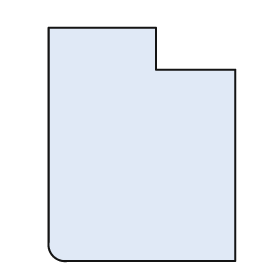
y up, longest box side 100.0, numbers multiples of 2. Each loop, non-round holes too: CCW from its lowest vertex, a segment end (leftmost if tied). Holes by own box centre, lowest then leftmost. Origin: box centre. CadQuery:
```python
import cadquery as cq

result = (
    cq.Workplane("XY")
    .moveTo(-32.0, -50.0)
    .lineTo(40.0, -50.0)
    .lineTo(40.0, 32.0)
    .lineTo(6.0, 32.0)
    .lineTo(6.0, 50.0)
    .lineTo(-40.0, 50.0)
    .lineTo(-40.0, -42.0)
    .threePointArc((-38.0, -48.0), (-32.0, -50.0))
    .close()
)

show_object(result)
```